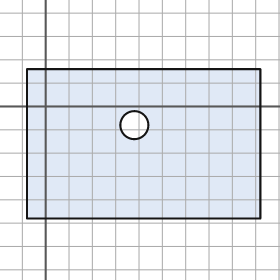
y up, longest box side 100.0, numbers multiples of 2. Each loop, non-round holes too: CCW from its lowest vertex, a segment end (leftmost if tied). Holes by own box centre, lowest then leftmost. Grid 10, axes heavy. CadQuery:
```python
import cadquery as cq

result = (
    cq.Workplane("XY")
    .moveTo(-8.0, -48.0)
    .lineTo(92.0, -48.0)
    .lineTo(92.0, 16.0)
    .lineTo(-8.0, 16.0)
    .close()
    .moveTo(38.0, -8.0)
    .circle(6.0)
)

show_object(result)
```